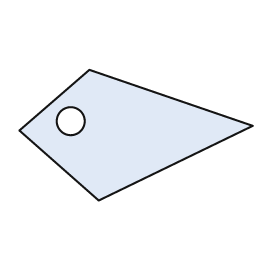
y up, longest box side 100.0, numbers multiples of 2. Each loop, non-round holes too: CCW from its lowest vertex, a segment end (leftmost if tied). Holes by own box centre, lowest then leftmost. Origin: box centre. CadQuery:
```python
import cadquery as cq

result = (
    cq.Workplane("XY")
    .moveTo(-16.0, -28.0)
    .lineTo(50.0, 4.0)
    .lineTo(-20.0, 28.0)
    .lineTo(-50.0, 2.0)
    .close()
    .moveTo(-28.0, 6.0)
    .circle(6.0)
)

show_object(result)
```